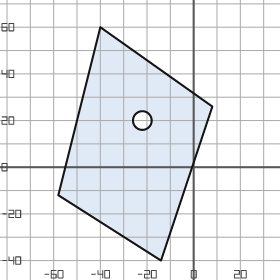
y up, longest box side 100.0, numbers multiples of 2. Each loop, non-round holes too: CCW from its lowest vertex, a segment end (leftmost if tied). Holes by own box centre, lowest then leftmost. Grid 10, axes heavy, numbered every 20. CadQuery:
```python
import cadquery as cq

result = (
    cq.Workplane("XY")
    .moveTo(-14.0, -40.0)
    .lineTo(8.0, 26.0)
    .lineTo(-40.0, 60.0)
    .lineTo(-58.0, -12.0)
    .close()
    .moveTo(-22.0, 20.0)
    .circle(4.0)
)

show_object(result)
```